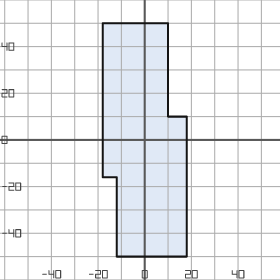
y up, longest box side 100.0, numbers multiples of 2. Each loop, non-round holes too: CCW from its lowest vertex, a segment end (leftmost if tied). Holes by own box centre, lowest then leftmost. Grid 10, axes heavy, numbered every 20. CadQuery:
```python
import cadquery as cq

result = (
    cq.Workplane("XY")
    .moveTo(-12.0, -50.0)
    .lineTo(18.0, -50.0)
    .lineTo(18.0, 10.0)
    .lineTo(10.0, 10.0)
    .lineTo(10.0, 50.0)
    .lineTo(-18.0, 50.0)
    .lineTo(-18.0, -16.0)
    .lineTo(-12.0, -16.0)
    .close()
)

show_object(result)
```